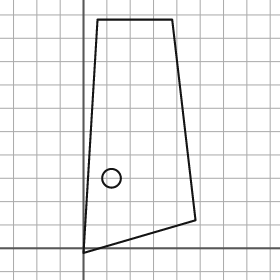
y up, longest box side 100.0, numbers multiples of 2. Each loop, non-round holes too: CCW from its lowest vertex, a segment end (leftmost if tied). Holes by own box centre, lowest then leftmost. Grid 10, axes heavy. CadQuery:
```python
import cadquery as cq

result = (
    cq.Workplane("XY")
    .moveTo(0.0, -2.0)
    .lineTo(48.0, 12.0)
    .lineTo(38.0, 98.0)
    .lineTo(6.0, 98.0)
    .close()
    .moveTo(12.0, 30.0)
    .circle(4.0)
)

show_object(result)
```